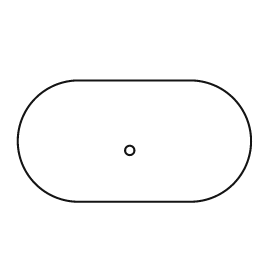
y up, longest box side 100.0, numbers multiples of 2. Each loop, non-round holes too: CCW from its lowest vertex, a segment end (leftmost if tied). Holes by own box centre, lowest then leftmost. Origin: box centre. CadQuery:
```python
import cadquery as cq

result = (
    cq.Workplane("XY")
    .moveTo(-24.0, -26.0)
    .lineTo(24.0, -26.0)
    .threePointArc((50.0, 0.0), (24.0, 26.0))
    .lineTo(-24.0, 26.0)
    .threePointArc((-50.0, 0.0), (-24.0, -26.0))
    .close()
    .moveTo(-2.0, -4.0)
    .circle(2.0)
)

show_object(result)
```